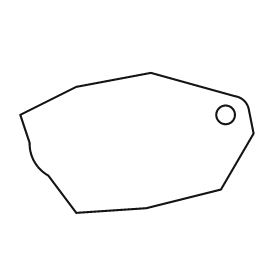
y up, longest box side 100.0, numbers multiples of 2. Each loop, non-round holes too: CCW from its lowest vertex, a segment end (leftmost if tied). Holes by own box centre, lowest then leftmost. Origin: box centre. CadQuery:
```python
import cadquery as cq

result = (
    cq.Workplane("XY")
    .moveTo(-26.0, -30.0)
    .lineTo(4.0, -28.0)
    .lineTo(36.0, -20.0)
    .lineTo(50.0, 4.0)
    .lineTo(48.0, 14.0)
    .threePointArc((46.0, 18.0), (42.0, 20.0))
    .lineTo(6.0, 30.0)
    .lineTo(-26.0, 24.0)
    .lineTo(-50.0, 12.0)
    .lineTo(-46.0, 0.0)
    .threePointArc((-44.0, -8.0), (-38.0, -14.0))
    .close()
    .moveTo(38.0, 12.0)
    .circle(4.0)
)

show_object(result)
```